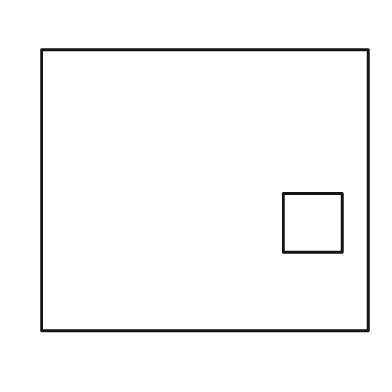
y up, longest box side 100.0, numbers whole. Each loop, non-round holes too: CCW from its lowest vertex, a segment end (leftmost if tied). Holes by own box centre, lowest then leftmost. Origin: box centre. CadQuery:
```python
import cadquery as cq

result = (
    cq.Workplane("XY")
    .moveTo(-50.0, -43.0)
    .lineTo(50.0, -43.0)
    .lineTo(50.0, 43.0)
    .lineTo(-50.0, 43.0)
    .close()
    .moveTo(24.0, -19.0)
    .lineTo(42.0, -19.0)
    .lineTo(42.0, -1.0)
    .lineTo(24.0, -1.0)
    .close()
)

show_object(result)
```